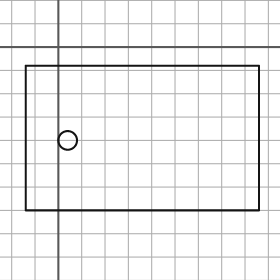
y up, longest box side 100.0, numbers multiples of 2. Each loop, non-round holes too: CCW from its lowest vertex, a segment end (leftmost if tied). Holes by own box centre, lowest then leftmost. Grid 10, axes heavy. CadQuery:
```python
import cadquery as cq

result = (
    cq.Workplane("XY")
    .moveTo(-14.0, -70.0)
    .lineTo(86.0, -70.0)
    .lineTo(86.0, -8.0)
    .lineTo(-14.0, -8.0)
    .close()
    .moveTo(4.0, -40.0)
    .circle(4.0)
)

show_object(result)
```